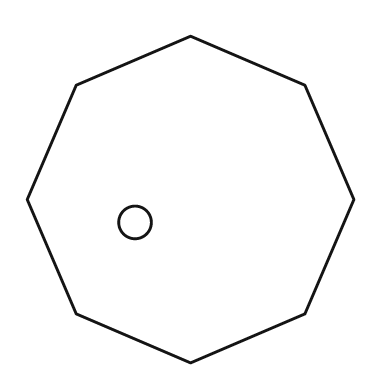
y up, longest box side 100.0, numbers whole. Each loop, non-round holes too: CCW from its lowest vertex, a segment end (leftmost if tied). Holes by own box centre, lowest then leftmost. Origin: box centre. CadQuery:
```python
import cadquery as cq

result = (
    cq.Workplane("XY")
    .moveTo(0.0, -50.0)
    .lineTo(35.0, -35.0)
    .lineTo(50.0, 0.0)
    .lineTo(35.0, 35.0)
    .lineTo(0.0, 50.0)
    .lineTo(-35.0, 35.0)
    .lineTo(-50.0, 0.0)
    .lineTo(-35.0, -35.0)
    .close()
    .moveTo(-17.0, -7.0)
    .circle(5.0)
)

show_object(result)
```